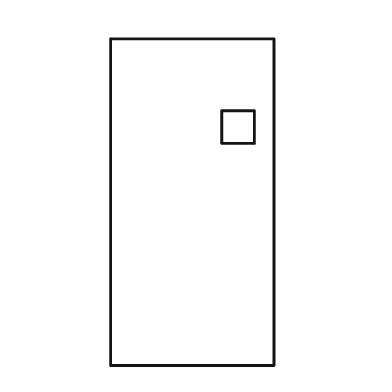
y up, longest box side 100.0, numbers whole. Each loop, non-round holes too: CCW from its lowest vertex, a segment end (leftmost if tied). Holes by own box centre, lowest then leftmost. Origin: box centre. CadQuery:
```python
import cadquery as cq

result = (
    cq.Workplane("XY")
    .moveTo(-25.0, -50.0)
    .lineTo(25.0, -50.0)
    .lineTo(25.0, 50.0)
    .lineTo(-25.0, 50.0)
    .close()
    .moveTo(9.0, 18.0)
    .lineTo(19.0, 18.0)
    .lineTo(19.0, 28.0)
    .lineTo(9.0, 28.0)
    .close()
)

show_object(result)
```